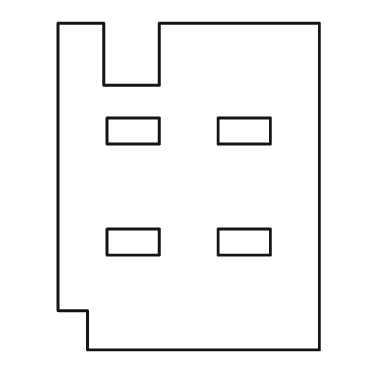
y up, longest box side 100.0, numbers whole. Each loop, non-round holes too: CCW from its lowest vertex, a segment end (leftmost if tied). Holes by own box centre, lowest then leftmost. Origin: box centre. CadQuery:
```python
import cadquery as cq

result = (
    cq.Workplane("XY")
    .moveTo(-31.0, -50.0)
    .lineTo(40.0, -50.0)
    .lineTo(40.0, 50.0)
    .lineTo(-9.0, 50.0)
    .lineTo(-9.0, 31.0)
    .lineTo(-26.0, 31.0)
    .lineTo(-26.0, 50.0)
    .lineTo(-40.0, 50.0)
    .lineTo(-40.0, -38.0)
    .lineTo(-31.0, -38.0)
    .close()
    .moveTo(-25.0, -21.0)
    .lineTo(-9.0, -21.0)
    .lineTo(-9.0, -13.0)
    .lineTo(-25.0, -13.0)
    .close()
    .moveTo(9.0, -21.0)
    .lineTo(25.0, -21.0)
    .lineTo(25.0, -13.0)
    .lineTo(9.0, -13.0)
    .close()
    .moveTo(-25.0, 13.0)
    .lineTo(-9.0, 13.0)
    .lineTo(-9.0, 21.0)
    .lineTo(-25.0, 21.0)
    .close()
    .moveTo(9.0, 13.0)
    .lineTo(25.0, 13.0)
    .lineTo(25.0, 21.0)
    .lineTo(9.0, 21.0)
    .close()
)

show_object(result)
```